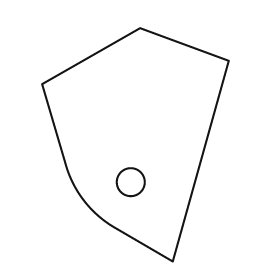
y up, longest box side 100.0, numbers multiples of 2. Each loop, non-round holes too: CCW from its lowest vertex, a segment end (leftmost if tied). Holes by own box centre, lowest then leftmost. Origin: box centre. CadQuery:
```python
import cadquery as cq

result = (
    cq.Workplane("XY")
    .moveTo(16.0, -50.0)
    .lineTo(40.0, 36.0)
    .lineTo(2.0, 50.0)
    .lineTo(-40.0, 26.0)
    .lineTo(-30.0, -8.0)
    .threePointArc((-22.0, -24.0), (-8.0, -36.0))
    .close()
    .moveTo(-2.0, -16.0)
    .circle(6.0)
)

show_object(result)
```